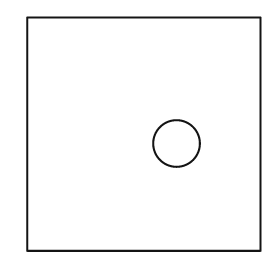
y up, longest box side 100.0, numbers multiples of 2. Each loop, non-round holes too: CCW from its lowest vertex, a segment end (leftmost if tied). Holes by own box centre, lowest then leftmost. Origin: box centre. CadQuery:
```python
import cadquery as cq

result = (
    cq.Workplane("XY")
    .moveTo(-50.0, -50.0)
    .lineTo(50.0, -50.0)
    .lineTo(50.0, 50.0)
    .lineTo(-50.0, 50.0)
    .close()
    .moveTo(14.0, -4.0)
    .circle(10.0)
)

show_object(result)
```